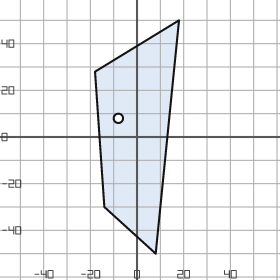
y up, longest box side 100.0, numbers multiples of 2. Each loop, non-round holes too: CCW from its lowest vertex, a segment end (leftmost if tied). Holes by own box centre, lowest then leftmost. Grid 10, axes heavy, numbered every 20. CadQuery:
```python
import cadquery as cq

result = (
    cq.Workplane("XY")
    .moveTo(8.0, -50.0)
    .lineTo(18.0, 50.0)
    .lineTo(-18.0, 28.0)
    .lineTo(-14.0, -30.0)
    .close()
    .moveTo(-8.0, 8.0)
    .circle(2.0)
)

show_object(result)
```